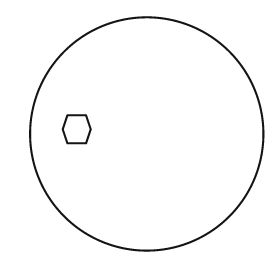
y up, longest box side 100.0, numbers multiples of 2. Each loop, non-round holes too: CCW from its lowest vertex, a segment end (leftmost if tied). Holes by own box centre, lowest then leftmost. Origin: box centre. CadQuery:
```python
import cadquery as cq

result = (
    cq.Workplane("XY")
    .moveTo(0.0, 0.0)
    .circle(50.0)
    .moveTo(-34.0, -4.0)
    .lineTo(-26.0, -4.0)
    .lineTo(-24.0, 2.0)
    .lineTo(-26.0, 8.0)
    .lineTo(-34.0, 8.0)
    .lineTo(-36.0, 2.0)
    .close()
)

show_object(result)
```